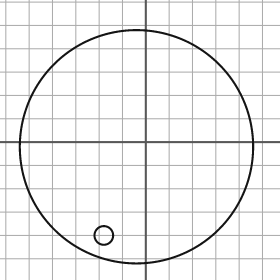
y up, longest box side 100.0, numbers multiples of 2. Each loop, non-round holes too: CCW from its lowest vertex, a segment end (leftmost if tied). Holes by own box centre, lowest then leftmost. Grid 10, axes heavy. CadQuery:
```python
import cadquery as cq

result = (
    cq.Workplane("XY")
    .moveTo(-4.0, -2.0)
    .circle(50.0)
    .moveTo(-18.0, -40.0)
    .circle(4.0)
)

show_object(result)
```